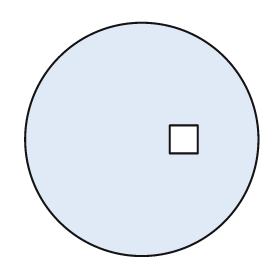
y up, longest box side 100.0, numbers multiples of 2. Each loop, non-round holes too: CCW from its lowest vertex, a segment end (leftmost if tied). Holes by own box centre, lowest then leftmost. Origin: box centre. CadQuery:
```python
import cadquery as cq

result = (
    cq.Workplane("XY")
    .moveTo(0.0, 0.0)
    .circle(50.0)
    .moveTo(12.0, -6.0)
    .lineTo(24.0, -6.0)
    .lineTo(24.0, 6.0)
    .lineTo(12.0, 6.0)
    .close()
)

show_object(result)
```